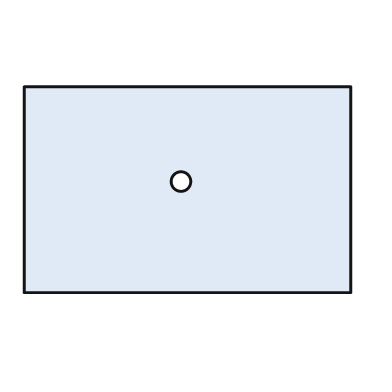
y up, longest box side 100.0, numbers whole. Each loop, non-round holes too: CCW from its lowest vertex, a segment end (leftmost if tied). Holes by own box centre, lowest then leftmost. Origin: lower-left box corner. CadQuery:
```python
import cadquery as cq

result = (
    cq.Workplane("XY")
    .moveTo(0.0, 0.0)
    .lineTo(100.0, 0.0)
    .lineTo(100.0, 63.0)
    .lineTo(0.0, 63.0)
    .close()
    .moveTo(48.0, 34.0)
    .circle(3.0)
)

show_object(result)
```